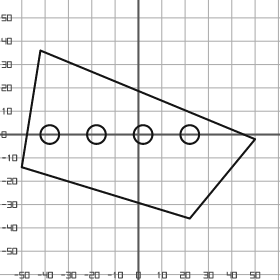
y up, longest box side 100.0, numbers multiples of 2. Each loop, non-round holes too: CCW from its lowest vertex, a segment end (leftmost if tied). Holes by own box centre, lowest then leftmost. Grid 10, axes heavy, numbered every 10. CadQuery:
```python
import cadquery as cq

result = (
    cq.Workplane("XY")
    .moveTo(22.0, -36.0)
    .lineTo(50.0, -2.0)
    .lineTo(-42.0, 36.0)
    .lineTo(-50.0, -14.0)
    .close()
    .moveTo(-38.0, 0.0)
    .circle(4.0)
    .moveTo(-18.0, 0.0)
    .circle(4.0)
    .moveTo(2.0, 0.0)
    .circle(4.0)
    .moveTo(22.0, 0.0)
    .circle(4.0)
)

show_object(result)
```